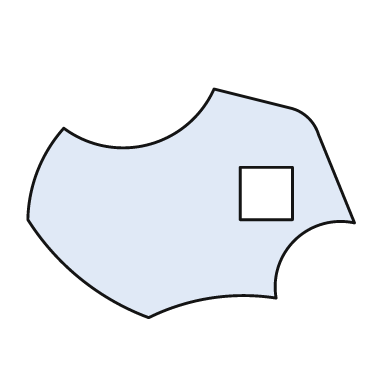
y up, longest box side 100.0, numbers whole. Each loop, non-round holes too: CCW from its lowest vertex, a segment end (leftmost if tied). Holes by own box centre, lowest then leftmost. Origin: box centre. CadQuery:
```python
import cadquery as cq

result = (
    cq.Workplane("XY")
    .moveTo(-13.0, -35.0)
    .threePointArc((6.0, -29.0), (26.0, -29.0))
    .threePointArc((32.0, -11.0), (50.0, -6.0))
    .lineTo(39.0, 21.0)
    .threePointArc((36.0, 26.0), (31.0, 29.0))
    .lineTo(7.0, 35.0)
    .threePointArc((-13.0, 18.0), (-39.0, 23.0))
    .threePointArc((-47.0, 10.0), (-50.0, -5.0))
    .threePointArc((-34.0, -23.0), (-13.0, -35.0))
    .close()
    .moveTo(15.0, -5.0)
    .lineTo(31.0, -5.0)
    .lineTo(31.0, 11.0)
    .lineTo(15.0, 11.0)
    .close()
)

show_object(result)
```